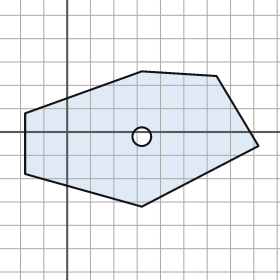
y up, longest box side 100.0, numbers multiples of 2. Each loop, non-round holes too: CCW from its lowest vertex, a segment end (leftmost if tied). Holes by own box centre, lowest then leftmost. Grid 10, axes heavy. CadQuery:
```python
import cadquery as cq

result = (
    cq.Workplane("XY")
    .moveTo(32.0, -32.0)
    .lineTo(82.0, -6.0)
    .lineTo(64.0, 24.0)
    .lineTo(32.0, 26.0)
    .lineTo(-18.0, 8.0)
    .lineTo(-18.0, -18.0)
    .close()
    .moveTo(32.0, -2.0)
    .circle(4.0)
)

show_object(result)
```